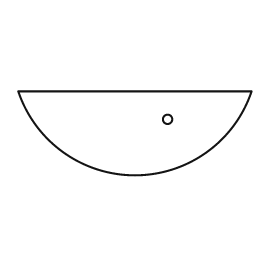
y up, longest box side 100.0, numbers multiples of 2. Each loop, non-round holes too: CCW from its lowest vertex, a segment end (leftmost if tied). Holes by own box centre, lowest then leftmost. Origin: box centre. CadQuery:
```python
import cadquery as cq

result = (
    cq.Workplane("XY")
    .moveTo(-50.0, 18.0)
    .threePointArc((0.0, -18.0), (50.0, 18.0))
    .close()
    .moveTo(14.0, 6.0)
    .circle(2.0)
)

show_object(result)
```